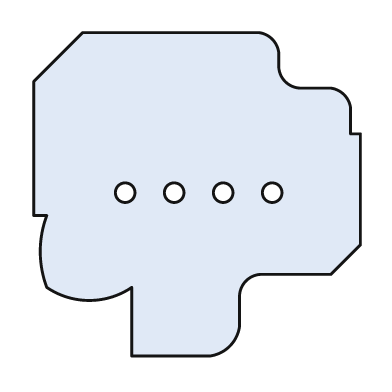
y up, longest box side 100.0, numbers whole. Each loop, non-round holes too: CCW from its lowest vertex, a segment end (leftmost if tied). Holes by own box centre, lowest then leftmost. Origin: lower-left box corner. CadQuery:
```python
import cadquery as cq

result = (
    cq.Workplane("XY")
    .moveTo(30.0, 0.0)
    .lineTo(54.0, 0.0)
    .threePointArc((60.0, 3.0), (63.0, 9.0))
    .lineTo(63.0, 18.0)
    .threePointArc((65.0, 23.0), (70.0, 25.0))
    .lineTo(91.0, 25.0)
    .lineTo(100.0, 34.0)
    .lineTo(100.0, 68.0)
    .lineTo(97.0, 68.0)
    .lineTo(97.0, 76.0)
    .threePointArc((95.0, 80.0), (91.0, 82.0))
    .lineTo(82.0, 82.0)
    .threePointArc((77.0, 84.0), (75.0, 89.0))
    .lineTo(75.0, 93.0)
    .threePointArc((73.0, 97.0), (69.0, 99.0))
    .lineTo(15.0, 99.0)
    .lineTo(0.0, 84.0)
    .lineTo(0.0, 43.0)
    .lineTo(4.0, 43.0)
    .threePointArc((2.0, 32.0), (4.0, 21.0))
    .threePointArc((17.0, 17.0), (30.0, 21.0))
    .close()
    .moveTo(28.0, 50.0)
    .circle(3.0)
    .moveTo(43.0, 50.0)
    .circle(3.0)
    .moveTo(58.0, 50.0)
    .circle(3.0)
    .moveTo(73.0, 50.0)
    .circle(3.0)
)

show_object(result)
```